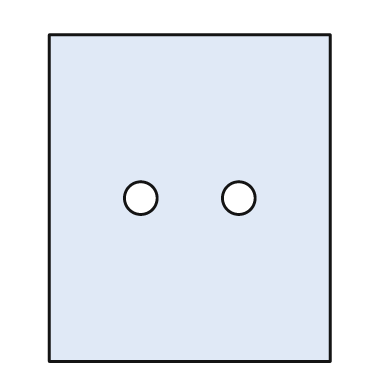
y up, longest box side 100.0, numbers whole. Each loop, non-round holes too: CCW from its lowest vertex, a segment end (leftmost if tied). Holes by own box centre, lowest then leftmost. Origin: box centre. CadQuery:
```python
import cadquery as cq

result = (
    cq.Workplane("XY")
    .moveTo(-43.0, -50.0)
    .lineTo(43.0, -50.0)
    .lineTo(43.0, 50.0)
    .lineTo(-43.0, 50.0)
    .close()
    .moveTo(-15.0, 0.0)
    .circle(5.0)
    .moveTo(15.0, 0.0)
    .circle(5.0)
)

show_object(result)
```